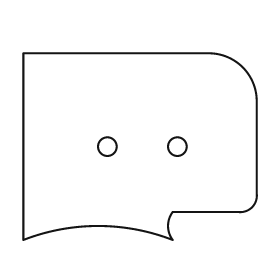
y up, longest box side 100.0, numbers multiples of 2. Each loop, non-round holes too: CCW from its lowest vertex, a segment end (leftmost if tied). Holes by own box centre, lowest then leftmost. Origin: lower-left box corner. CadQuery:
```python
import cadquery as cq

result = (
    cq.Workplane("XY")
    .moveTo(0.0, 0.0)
    .threePointArc((32.0, 6.0), (64.0, 0.0))
    .threePointArc((62.0, 6.0), (64.0, 12.0))
    .lineTo(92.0, 12.0)
    .threePointArc((98.0, 14.0), (100.0, 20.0))
    .lineTo(100.0, 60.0)
    .threePointArc((94.0, 74.0), (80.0, 80.0))
    .lineTo(0.0, 80.0)
    .close()
    .moveTo(36.0, 40.0)
    .circle(4.0)
    .moveTo(66.0, 40.0)
    .circle(4.0)
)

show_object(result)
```